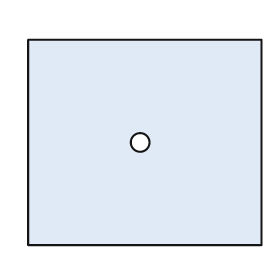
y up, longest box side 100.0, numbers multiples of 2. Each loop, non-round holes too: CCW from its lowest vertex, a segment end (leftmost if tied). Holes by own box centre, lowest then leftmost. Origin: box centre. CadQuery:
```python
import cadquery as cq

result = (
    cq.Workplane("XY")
    .moveTo(-50.0, -44.0)
    .lineTo(50.0, -44.0)
    .lineTo(50.0, 44.0)
    .lineTo(-50.0, 44.0)
    .close()
    .moveTo(-2.0, 0.0)
    .circle(4.0)
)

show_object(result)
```